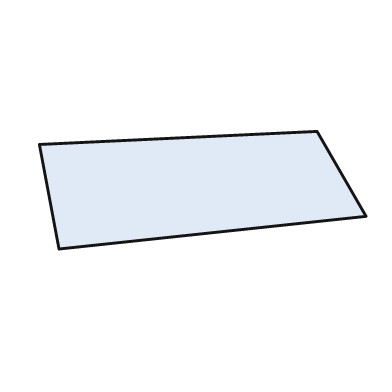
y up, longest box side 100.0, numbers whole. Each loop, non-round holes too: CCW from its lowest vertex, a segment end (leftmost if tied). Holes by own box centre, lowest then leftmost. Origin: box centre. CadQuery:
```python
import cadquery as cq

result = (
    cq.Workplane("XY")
    .moveTo(-44.0, -18.0)
    .lineTo(50.0, -8.0)
    .lineTo(35.0, 18.0)
    .lineTo(-50.0, 14.0)
    .close()
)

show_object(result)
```